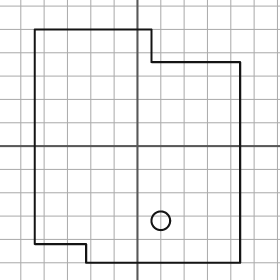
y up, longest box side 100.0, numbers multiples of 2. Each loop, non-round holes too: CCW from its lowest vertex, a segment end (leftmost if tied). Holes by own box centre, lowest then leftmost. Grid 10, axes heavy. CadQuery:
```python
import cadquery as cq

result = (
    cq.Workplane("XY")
    .moveTo(-22.0, -50.0)
    .lineTo(44.0, -50.0)
    .lineTo(44.0, 36.0)
    .lineTo(6.0, 36.0)
    .lineTo(6.0, 50.0)
    .lineTo(-44.0, 50.0)
    .lineTo(-44.0, -42.0)
    .lineTo(-22.0, -42.0)
    .close()
    .moveTo(10.0, -32.0)
    .circle(4.0)
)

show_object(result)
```